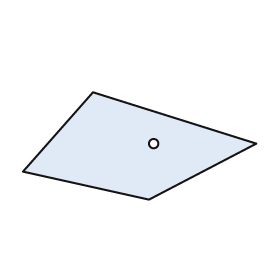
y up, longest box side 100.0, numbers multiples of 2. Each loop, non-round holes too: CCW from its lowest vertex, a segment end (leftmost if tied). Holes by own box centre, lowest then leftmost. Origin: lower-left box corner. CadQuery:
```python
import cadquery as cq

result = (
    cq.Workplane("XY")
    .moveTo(54.0, 0.0)
    .lineTo(100.0, 24.0)
    .lineTo(30.0, 46.0)
    .lineTo(0.0, 12.0)
    .close()
    .moveTo(56.0, 24.0)
    .circle(2.0)
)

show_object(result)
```